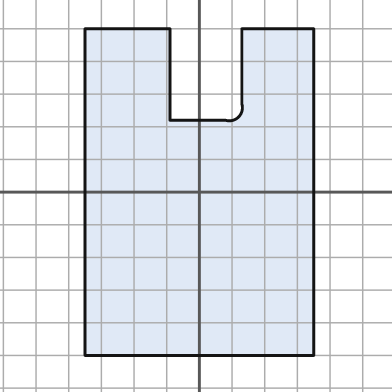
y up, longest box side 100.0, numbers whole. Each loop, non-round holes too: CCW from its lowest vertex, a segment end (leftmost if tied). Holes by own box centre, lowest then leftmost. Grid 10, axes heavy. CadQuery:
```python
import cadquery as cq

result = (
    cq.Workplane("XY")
    .moveTo(-35.0, -50.0)
    .lineTo(35.0, -50.0)
    .lineTo(35.0, 50.0)
    .lineTo(13.0, 50.0)
    .lineTo(13.0, 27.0)
    .threePointArc((12.0, 23.0), (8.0, 22.0))
    .lineTo(-9.0, 22.0)
    .lineTo(-9.0, 50.0)
    .lineTo(-35.0, 50.0)
    .close()
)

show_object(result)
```